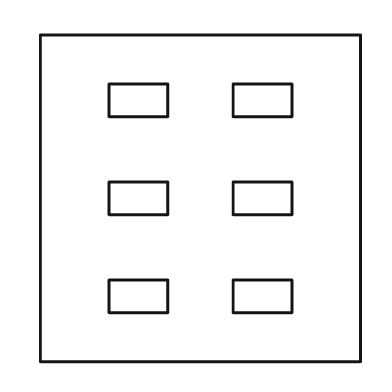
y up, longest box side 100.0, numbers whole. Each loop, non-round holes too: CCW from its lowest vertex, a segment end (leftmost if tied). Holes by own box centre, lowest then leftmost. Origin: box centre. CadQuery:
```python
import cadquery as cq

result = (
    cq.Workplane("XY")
    .moveTo(-49.0, -50.0)
    .lineTo(49.0, -50.0)
    .lineTo(49.0, 50.0)
    .lineTo(-49.0, 50.0)
    .close()
    .moveTo(-28.0, -35.0)
    .lineTo(-10.0, -35.0)
    .lineTo(-10.0, -25.0)
    .lineTo(-28.0, -25.0)
    .close()
    .moveTo(10.0, -35.0)
    .lineTo(28.0, -35.0)
    .lineTo(28.0, -25.0)
    .lineTo(10.0, -25.0)
    .close()
    .moveTo(-28.0, -5.0)
    .lineTo(-10.0, -5.0)
    .lineTo(-10.0, 5.0)
    .lineTo(-28.0, 5.0)
    .close()
    .moveTo(10.0, -5.0)
    .lineTo(28.0, -5.0)
    .lineTo(28.0, 5.0)
    .lineTo(10.0, 5.0)
    .close()
    .moveTo(-28.0, 25.0)
    .lineTo(-10.0, 25.0)
    .lineTo(-10.0, 35.0)
    .lineTo(-28.0, 35.0)
    .close()
    .moveTo(10.0, 25.0)
    .lineTo(28.0, 25.0)
    .lineTo(28.0, 35.0)
    .lineTo(10.0, 35.0)
    .close()
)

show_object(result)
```